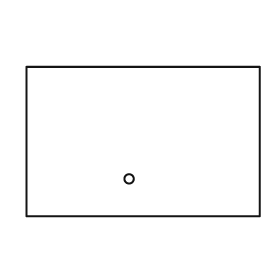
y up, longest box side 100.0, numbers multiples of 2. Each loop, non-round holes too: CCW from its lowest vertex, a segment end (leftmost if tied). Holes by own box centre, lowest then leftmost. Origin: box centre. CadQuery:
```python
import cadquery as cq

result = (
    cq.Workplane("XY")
    .moveTo(-50.0, -32.0)
    .lineTo(50.0, -32.0)
    .lineTo(50.0, 32.0)
    .lineTo(-50.0, 32.0)
    .close()
    .moveTo(-6.0, -16.0)
    .circle(2.0)
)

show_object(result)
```